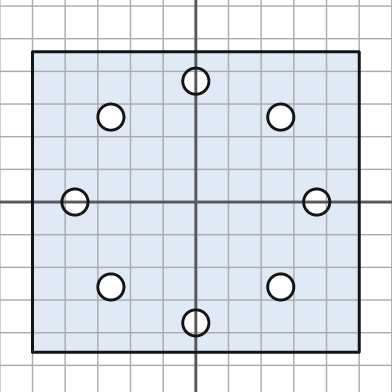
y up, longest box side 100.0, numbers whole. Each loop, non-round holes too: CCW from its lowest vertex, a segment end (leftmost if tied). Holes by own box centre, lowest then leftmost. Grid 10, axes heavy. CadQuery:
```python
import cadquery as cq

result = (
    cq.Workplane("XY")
    .moveTo(-50.0, -46.0)
    .lineTo(50.0, -46.0)
    .lineTo(50.0, 46.0)
    .lineTo(-50.0, 46.0)
    .close()
    .moveTo(0.0, -37.0)
    .circle(4.0)
    .moveTo(-26.0, -26.0)
    .circle(4.0)
    .moveTo(26.0, -26.0)
    .circle(4.0)
    .moveTo(-37.0, 0.0)
    .circle(4.0)
    .moveTo(37.0, 0.0)
    .circle(4.0)
    .moveTo(-26.0, 26.0)
    .circle(4.0)
    .moveTo(26.0, 26.0)
    .circle(4.0)
    .moveTo(0.0, 37.0)
    .circle(4.0)
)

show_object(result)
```